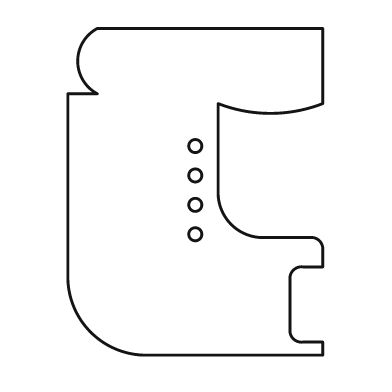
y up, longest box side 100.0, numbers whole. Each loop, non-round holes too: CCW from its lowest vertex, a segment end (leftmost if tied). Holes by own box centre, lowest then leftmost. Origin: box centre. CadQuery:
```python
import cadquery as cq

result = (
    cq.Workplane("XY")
    .moveTo(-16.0, -50.0)
    .lineTo(39.0, -50.0)
    .lineTo(39.0, -46.0)
    .lineTo(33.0, -46.0)
    .threePointArc((30.0, -45.0), (29.0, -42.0))
    .lineTo(29.0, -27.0)
    .threePointArc((30.0, -24.0), (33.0, -23.0))
    .lineTo(39.0, -23.0)
    .lineTo(39.0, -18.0)
    .threePointArc((38.0, -15.0), (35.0, -14.0))
    .lineTo(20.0, -14.0)
    .threePointArc((11.0, -10.0), (7.0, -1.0))
    .lineTo(7.0, 27.0)
    .threePointArc((23.0, 24.0), (39.0, 27.0))
    .lineTo(39.0, 50.0)
    .lineTo(-30.0, 50.0)
    .threePointArc((-36.0, 40.0), (-30.0, 30.0))
    .lineTo(-39.0, 30.0)
    .lineTo(-39.0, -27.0)
    .threePointArc((-32.0, -43.0), (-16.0, -50.0))
    .close()
    .moveTo(0.0, -13.0)
    .circle(2.0)
    .moveTo(0.0, -4.0)
    .circle(2.0)
    .moveTo(0.0, 5.0)
    .circle(2.0)
    .moveTo(0.0, 14.0)
    .circle(2.0)
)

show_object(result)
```